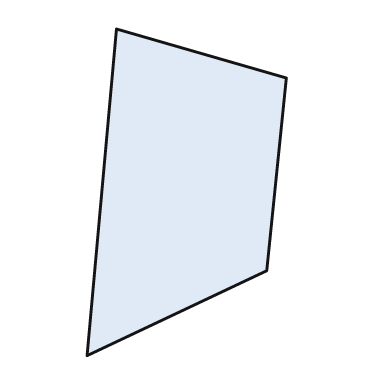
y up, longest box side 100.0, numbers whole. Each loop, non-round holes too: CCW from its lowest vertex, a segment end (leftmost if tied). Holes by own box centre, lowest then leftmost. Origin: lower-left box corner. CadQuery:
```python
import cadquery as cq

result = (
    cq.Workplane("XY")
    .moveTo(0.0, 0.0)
    .lineTo(55.0, 26.0)
    .lineTo(61.0, 85.0)
    .lineTo(9.0, 100.0)
    .close()
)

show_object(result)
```